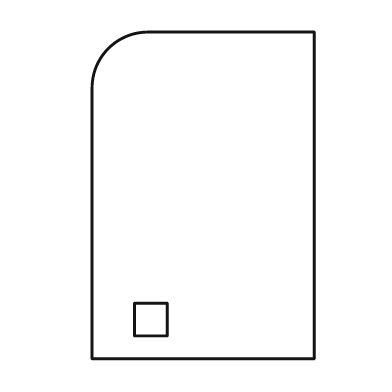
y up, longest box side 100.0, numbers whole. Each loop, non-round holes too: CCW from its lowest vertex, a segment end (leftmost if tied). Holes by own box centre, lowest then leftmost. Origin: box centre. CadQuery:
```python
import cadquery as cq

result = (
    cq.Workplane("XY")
    .moveTo(-34.0, -50.0)
    .lineTo(34.0, -50.0)
    .lineTo(34.0, 50.0)
    .lineTo(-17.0, 50.0)
    .threePointArc((-29.0, 45.0), (-34.0, 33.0))
    .close()
    .moveTo(-21.0, -43.0)
    .lineTo(-11.0, -43.0)
    .lineTo(-11.0, -33.0)
    .lineTo(-21.0, -33.0)
    .close()
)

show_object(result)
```